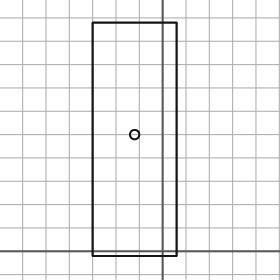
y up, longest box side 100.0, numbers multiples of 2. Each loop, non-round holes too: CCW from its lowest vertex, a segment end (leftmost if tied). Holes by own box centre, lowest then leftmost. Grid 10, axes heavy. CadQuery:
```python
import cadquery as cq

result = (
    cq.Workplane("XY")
    .moveTo(-30.0, -2.0)
    .lineTo(6.0, -2.0)
    .lineTo(6.0, 98.0)
    .lineTo(-30.0, 98.0)
    .close()
    .moveTo(-12.0, 50.0)
    .circle(2.0)
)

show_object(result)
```